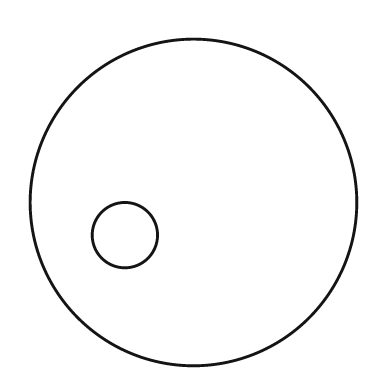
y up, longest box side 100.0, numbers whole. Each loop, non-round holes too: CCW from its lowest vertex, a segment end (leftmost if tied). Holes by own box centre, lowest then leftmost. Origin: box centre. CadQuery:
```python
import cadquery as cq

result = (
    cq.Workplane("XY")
    .moveTo(0.0, 0.0)
    .circle(50.0)
    .moveTo(-21.0, -10.0)
    .circle(10.0)
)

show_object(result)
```